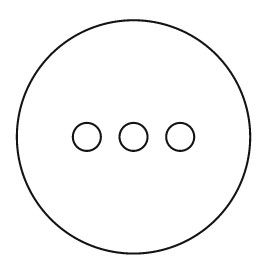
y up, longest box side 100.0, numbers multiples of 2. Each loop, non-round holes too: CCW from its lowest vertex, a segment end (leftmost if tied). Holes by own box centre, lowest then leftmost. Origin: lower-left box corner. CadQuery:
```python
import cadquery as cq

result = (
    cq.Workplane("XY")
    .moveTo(50.0, 50.0)
    .circle(50.0)
    .moveTo(30.0, 50.0)
    .circle(6.0)
    .moveTo(50.0, 50.0)
    .circle(6.0)
    .moveTo(70.0, 50.0)
    .circle(6.0)
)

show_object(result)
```